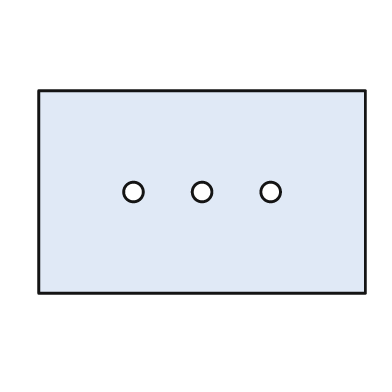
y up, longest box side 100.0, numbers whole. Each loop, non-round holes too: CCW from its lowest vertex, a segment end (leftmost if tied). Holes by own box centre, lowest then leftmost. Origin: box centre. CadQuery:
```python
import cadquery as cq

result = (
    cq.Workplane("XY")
    .moveTo(-50.0, -31.0)
    .lineTo(50.0, -31.0)
    .lineTo(50.0, 31.0)
    .lineTo(-50.0, 31.0)
    .close()
    .moveTo(-21.0, 0.0)
    .circle(3.0)
    .moveTo(0.0, 0.0)
    .circle(3.0)
    .moveTo(21.0, 0.0)
    .circle(3.0)
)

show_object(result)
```